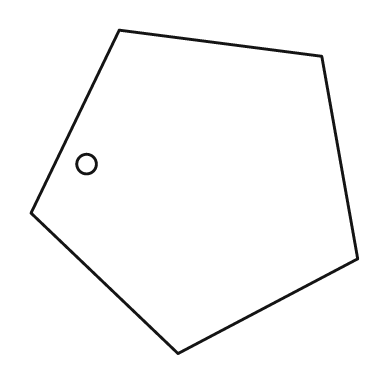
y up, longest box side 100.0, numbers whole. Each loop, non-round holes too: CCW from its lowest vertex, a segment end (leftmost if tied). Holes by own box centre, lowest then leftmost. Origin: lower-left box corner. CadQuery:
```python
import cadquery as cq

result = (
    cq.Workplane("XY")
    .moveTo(45.0, 0.0)
    .lineTo(100.0, 29.0)
    .lineTo(89.0, 91.0)
    .lineTo(27.0, 99.0)
    .lineTo(0.0, 43.0)
    .close()
    .moveTo(17.0, 58.0)
    .circle(3.0)
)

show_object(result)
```